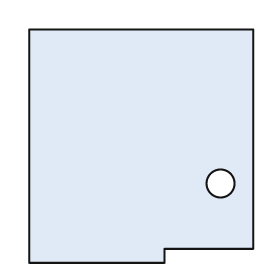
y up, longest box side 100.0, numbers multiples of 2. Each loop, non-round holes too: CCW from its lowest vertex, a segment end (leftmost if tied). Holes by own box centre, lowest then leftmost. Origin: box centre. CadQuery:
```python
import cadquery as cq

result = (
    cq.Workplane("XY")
    .moveTo(-48.0, -50.0)
    .lineTo(10.0, -50.0)
    .lineTo(10.0, -44.0)
    .lineTo(48.0, -44.0)
    .lineTo(48.0, 50.0)
    .lineTo(-48.0, 50.0)
    .close()
    .moveTo(34.0, -16.0)
    .circle(6.0)
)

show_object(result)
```